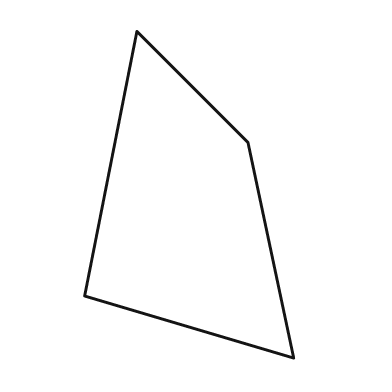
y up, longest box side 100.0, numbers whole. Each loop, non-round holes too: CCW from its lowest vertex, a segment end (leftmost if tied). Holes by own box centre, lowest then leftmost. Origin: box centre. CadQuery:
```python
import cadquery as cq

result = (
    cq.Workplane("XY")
    .moveTo(32.0, -50.0)
    .lineTo(18.0, 16.0)
    .lineTo(-16.0, 50.0)
    .lineTo(-32.0, -31.0)
    .close()
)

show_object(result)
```